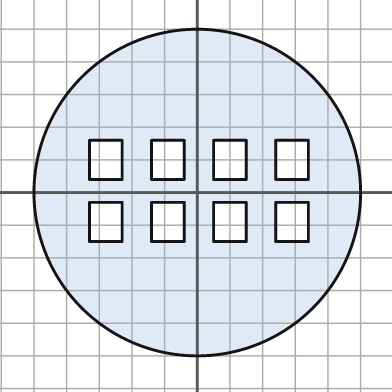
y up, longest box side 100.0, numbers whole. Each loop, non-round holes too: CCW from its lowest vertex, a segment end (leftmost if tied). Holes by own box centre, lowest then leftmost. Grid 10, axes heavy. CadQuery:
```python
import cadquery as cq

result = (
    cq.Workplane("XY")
    .moveTo(0.0, 0.0)
    .circle(50.0)
    .moveTo(-33.0, -15.0)
    .lineTo(-23.0, -15.0)
    .lineTo(-23.0, -3.0)
    .lineTo(-33.0, -3.0)
    .close()
    .moveTo(-14.0, -15.0)
    .lineTo(-4.0, -15.0)
    .lineTo(-4.0, -3.0)
    .lineTo(-14.0, -3.0)
    .close()
    .moveTo(5.0, -15.0)
    .lineTo(15.0, -15.0)
    .lineTo(15.0, -3.0)
    .lineTo(5.0, -3.0)
    .close()
    .moveTo(24.0, -15.0)
    .lineTo(34.0, -15.0)
    .lineTo(34.0, -3.0)
    .lineTo(24.0, -3.0)
    .close()
    .moveTo(-33.0, 4.0)
    .lineTo(-23.0, 4.0)
    .lineTo(-23.0, 16.0)
    .lineTo(-33.0, 16.0)
    .close()
    .moveTo(-14.0, 4.0)
    .lineTo(-4.0, 4.0)
    .lineTo(-4.0, 16.0)
    .lineTo(-14.0, 16.0)
    .close()
    .moveTo(5.0, 4.0)
    .lineTo(15.0, 4.0)
    .lineTo(15.0, 16.0)
    .lineTo(5.0, 16.0)
    .close()
    .moveTo(24.0, 4.0)
    .lineTo(34.0, 4.0)
    .lineTo(34.0, 16.0)
    .lineTo(24.0, 16.0)
    .close()
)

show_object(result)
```